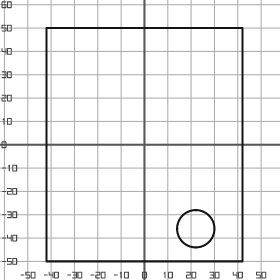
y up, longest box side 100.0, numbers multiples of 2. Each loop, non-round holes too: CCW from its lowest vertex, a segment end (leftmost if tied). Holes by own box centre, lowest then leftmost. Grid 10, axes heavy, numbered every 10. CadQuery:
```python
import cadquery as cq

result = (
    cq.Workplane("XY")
    .moveTo(-42.0, -50.0)
    .lineTo(42.0, -50.0)
    .lineTo(42.0, 50.0)
    .lineTo(-42.0, 50.0)
    .close()
    .moveTo(22.0, -36.0)
    .circle(8.0)
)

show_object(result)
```